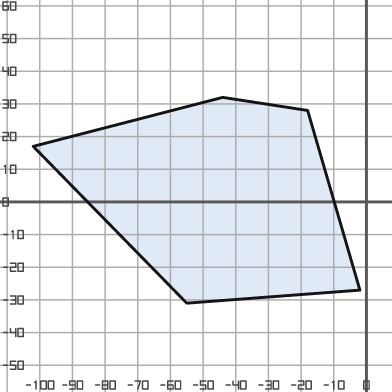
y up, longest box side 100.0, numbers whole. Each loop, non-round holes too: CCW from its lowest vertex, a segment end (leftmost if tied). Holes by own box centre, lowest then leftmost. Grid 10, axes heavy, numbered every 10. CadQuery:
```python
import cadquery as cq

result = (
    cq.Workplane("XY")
    .moveTo(-55.0, -31.0)
    .lineTo(-2.0, -27.0)
    .lineTo(-18.0, 28.0)
    .lineTo(-44.0, 32.0)
    .lineTo(-102.0, 17.0)
    .close()
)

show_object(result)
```